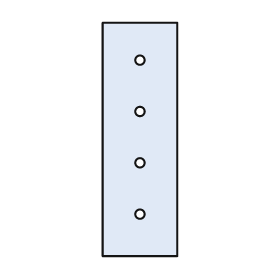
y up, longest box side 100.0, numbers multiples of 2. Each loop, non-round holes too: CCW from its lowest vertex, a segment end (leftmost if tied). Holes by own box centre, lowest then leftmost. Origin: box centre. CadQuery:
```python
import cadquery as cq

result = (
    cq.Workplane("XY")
    .moveTo(-16.0, -50.0)
    .lineTo(16.0, -50.0)
    .lineTo(16.0, 50.0)
    .lineTo(-16.0, 50.0)
    .close()
    .moveTo(0.0, -32.0)
    .circle(2.0)
    .moveTo(0.0, -10.0)
    .circle(2.0)
    .moveTo(0.0, 12.0)
    .circle(2.0)
    .moveTo(0.0, 34.0)
    .circle(2.0)
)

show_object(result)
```